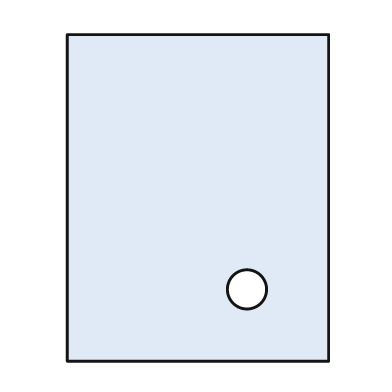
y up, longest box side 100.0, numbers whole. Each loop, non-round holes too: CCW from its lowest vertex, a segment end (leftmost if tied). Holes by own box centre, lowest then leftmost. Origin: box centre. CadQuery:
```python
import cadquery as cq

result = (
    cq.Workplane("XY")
    .moveTo(-40.0, -50.0)
    .lineTo(40.0, -50.0)
    .lineTo(40.0, 50.0)
    .lineTo(-40.0, 50.0)
    .close()
    .moveTo(15.0, -28.0)
    .circle(6.0)
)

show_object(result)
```